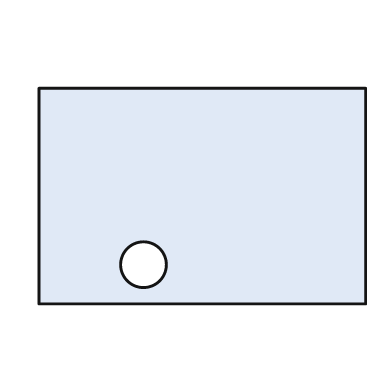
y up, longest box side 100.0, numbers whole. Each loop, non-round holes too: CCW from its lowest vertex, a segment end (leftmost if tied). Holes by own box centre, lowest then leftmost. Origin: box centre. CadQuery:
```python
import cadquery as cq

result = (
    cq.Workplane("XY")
    .moveTo(-50.0, -33.0)
    .lineTo(50.0, -33.0)
    .lineTo(50.0, 33.0)
    .lineTo(-50.0, 33.0)
    .close()
    .moveTo(-18.0, -21.0)
    .circle(7.0)
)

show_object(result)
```